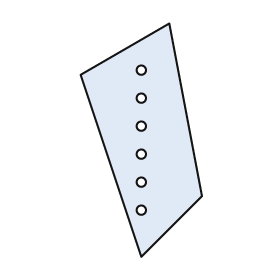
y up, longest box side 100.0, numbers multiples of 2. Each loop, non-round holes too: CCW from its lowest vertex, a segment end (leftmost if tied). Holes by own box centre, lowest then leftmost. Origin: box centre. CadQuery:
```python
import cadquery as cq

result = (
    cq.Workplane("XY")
    .moveTo(0.0, -50.0)
    .lineTo(26.0, -24.0)
    .lineTo(12.0, 50.0)
    .lineTo(-26.0, 28.0)
    .close()
    .moveTo(0.0, -30.0)
    .circle(2.0)
    .moveTo(0.0, -18.0)
    .circle(2.0)
    .moveTo(0.0, -6.0)
    .circle(2.0)
    .moveTo(0.0, 6.0)
    .circle(2.0)
    .moveTo(0.0, 18.0)
    .circle(2.0)
    .moveTo(0.0, 30.0)
    .circle(2.0)
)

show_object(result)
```